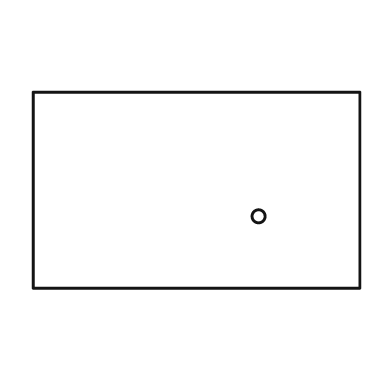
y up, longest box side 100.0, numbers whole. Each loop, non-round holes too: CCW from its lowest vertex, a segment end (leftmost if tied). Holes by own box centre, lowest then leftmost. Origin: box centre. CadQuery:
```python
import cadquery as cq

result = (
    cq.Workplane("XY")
    .moveTo(-50.0, -30.0)
    .lineTo(50.0, -30.0)
    .lineTo(50.0, 30.0)
    .lineTo(-50.0, 30.0)
    .close()
    .moveTo(19.0, -8.0)
    .circle(2.0)
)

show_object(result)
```